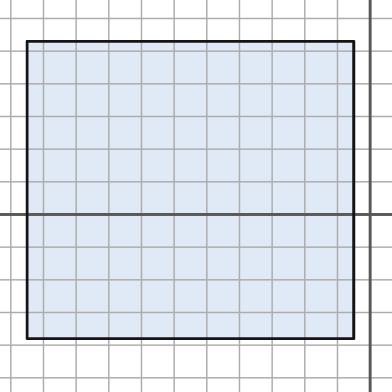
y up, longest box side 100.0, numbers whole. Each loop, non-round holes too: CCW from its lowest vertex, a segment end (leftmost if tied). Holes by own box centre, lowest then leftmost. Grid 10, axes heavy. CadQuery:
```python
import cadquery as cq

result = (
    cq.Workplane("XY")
    .moveTo(-105.0, -38.0)
    .lineTo(-5.0, -38.0)
    .lineTo(-5.0, 53.0)
    .lineTo(-105.0, 53.0)
    .close()
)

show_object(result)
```